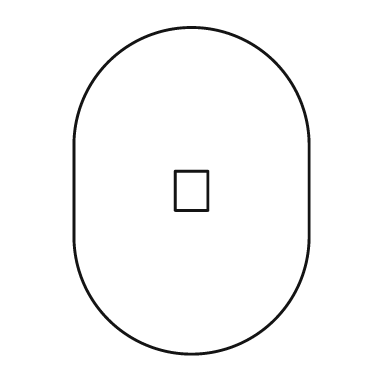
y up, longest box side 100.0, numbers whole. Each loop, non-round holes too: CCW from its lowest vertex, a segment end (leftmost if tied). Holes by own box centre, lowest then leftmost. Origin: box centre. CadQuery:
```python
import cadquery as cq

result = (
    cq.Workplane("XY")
    .moveTo(-36.0, -14.0)
    .threePointArc((0.0, -50.0), (36.0, -14.0))
    .lineTo(36.0, 14.0)
    .threePointArc((0.0, 50.0), (-36.0, 14.0))
    .close()
    .moveTo(-5.0, -6.0)
    .lineTo(5.0, -6.0)
    .lineTo(5.0, 6.0)
    .lineTo(-5.0, 6.0)
    .close()
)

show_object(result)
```